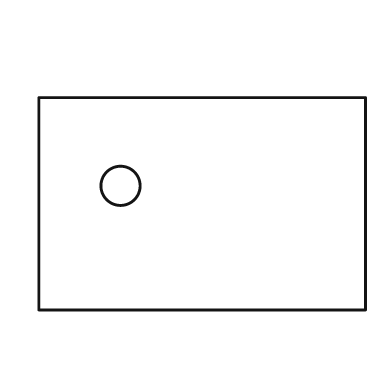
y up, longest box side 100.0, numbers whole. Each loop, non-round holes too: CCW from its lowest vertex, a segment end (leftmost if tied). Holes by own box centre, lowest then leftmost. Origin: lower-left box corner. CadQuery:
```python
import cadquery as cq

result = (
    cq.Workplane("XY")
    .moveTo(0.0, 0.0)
    .lineTo(100.0, 0.0)
    .lineTo(100.0, 65.0)
    .lineTo(0.0, 65.0)
    .close()
    .moveTo(25.0, 38.0)
    .circle(6.0)
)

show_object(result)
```